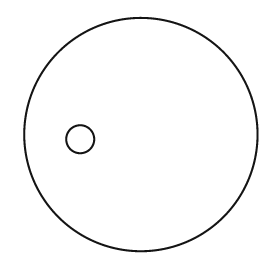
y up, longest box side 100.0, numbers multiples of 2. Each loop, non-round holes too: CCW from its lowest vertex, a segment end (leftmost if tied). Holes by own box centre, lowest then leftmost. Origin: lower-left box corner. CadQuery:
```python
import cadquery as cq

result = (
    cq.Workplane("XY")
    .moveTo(50.0, 50.0)
    .circle(50.0)
    .moveTo(24.0, 48.0)
    .circle(6.0)
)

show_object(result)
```